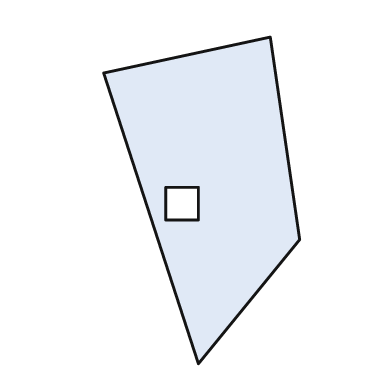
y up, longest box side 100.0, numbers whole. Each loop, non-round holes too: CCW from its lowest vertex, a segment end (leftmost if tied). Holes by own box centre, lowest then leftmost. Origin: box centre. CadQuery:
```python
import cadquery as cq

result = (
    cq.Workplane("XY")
    .moveTo(-1.0, -50.0)
    .lineTo(30.0, -12.0)
    .lineTo(21.0, 50.0)
    .lineTo(-30.0, 39.0)
    .close()
    .moveTo(-11.0, -6.0)
    .lineTo(-1.0, -6.0)
    .lineTo(-1.0, 4.0)
    .lineTo(-11.0, 4.0)
    .close()
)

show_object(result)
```